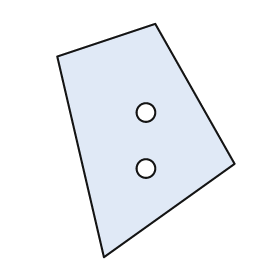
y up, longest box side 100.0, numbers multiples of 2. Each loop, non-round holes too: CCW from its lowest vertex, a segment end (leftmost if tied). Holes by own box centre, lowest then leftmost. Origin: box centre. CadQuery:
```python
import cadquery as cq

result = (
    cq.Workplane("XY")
    .moveTo(-18.0, -50.0)
    .lineTo(38.0, -10.0)
    .lineTo(4.0, 50.0)
    .lineTo(-38.0, 36.0)
    .close()
    .moveTo(0.0, -12.0)
    .circle(4.0)
    .moveTo(0.0, 12.0)
    .circle(4.0)
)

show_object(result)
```